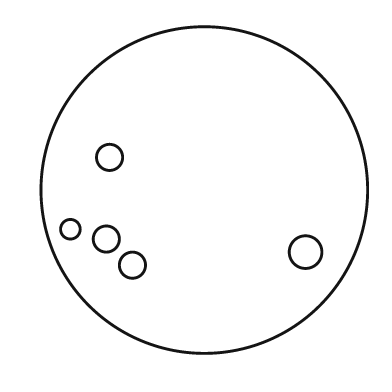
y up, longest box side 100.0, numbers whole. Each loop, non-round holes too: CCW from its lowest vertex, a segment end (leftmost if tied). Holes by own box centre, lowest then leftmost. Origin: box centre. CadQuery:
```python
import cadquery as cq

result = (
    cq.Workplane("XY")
    .moveTo(0.0, 0.0)
    .circle(50.0)
    .moveTo(-22.0, -23.0)
    .circle(4.0)
    .moveTo(31.0, -19.0)
    .circle(5.0)
    .moveTo(-30.0, -15.0)
    .circle(4.0)
    .moveTo(-41.0, -12.0)
    .circle(3.0)
    .moveTo(-29.0, 10.0)
    .circle(4.0)
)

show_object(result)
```